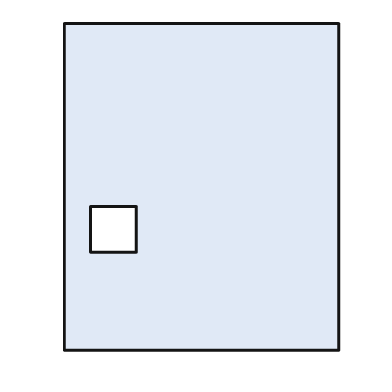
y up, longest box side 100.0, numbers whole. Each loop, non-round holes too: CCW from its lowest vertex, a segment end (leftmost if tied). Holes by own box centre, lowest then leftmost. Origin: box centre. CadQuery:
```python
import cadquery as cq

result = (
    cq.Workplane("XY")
    .moveTo(-42.0, -50.0)
    .lineTo(42.0, -50.0)
    .lineTo(42.0, 50.0)
    .lineTo(-42.0, 50.0)
    .close()
    .moveTo(-34.0, -20.0)
    .lineTo(-20.0, -20.0)
    .lineTo(-20.0, -6.0)
    .lineTo(-34.0, -6.0)
    .close()
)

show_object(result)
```